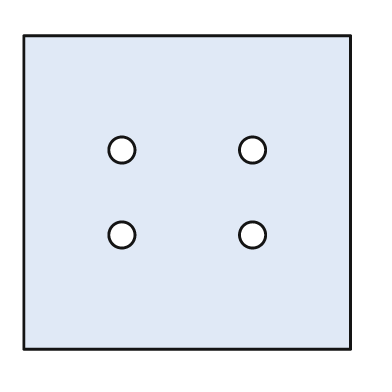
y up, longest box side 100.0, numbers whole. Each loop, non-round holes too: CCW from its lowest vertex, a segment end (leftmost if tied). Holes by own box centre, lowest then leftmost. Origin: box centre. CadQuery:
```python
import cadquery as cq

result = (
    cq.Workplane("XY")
    .moveTo(-50.0, -48.0)
    .lineTo(50.0, -48.0)
    .lineTo(50.0, 48.0)
    .lineTo(-50.0, 48.0)
    .close()
    .moveTo(-20.0, -13.0)
    .circle(4.0)
    .moveTo(20.0, -13.0)
    .circle(4.0)
    .moveTo(-20.0, 13.0)
    .circle(4.0)
    .moveTo(20.0, 13.0)
    .circle(4.0)
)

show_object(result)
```